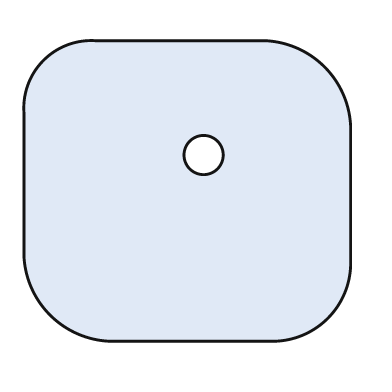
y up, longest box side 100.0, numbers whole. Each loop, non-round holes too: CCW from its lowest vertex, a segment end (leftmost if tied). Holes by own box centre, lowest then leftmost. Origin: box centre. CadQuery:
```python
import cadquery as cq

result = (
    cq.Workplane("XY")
    .moveTo(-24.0, -46.0)
    .lineTo(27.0, -46.0)
    .threePointArc((43.0, -39.0), (50.0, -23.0))
    .lineTo(50.0, 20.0)
    .threePointArc((42.0, 38.0), (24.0, 46.0))
    .lineTo(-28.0, 46.0)
    .threePointArc((-44.0, 40.0), (-50.0, 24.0))
    .lineTo(-50.0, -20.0)
    .threePointArc((-42.0, -38.0), (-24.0, -46.0))
    .close()
    .moveTo(5.0, 11.0)
    .circle(6.0)
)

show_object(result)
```